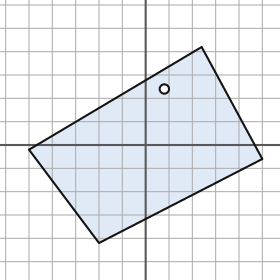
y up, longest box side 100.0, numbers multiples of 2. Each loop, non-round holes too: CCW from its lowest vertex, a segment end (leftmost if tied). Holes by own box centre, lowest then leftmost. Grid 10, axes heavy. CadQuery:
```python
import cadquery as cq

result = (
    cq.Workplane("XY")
    .moveTo(-20.0, -42.0)
    .lineTo(50.0, -6.0)
    .lineTo(24.0, 42.0)
    .lineTo(-50.0, -2.0)
    .close()
    .moveTo(8.0, 24.0)
    .circle(2.0)
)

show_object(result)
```